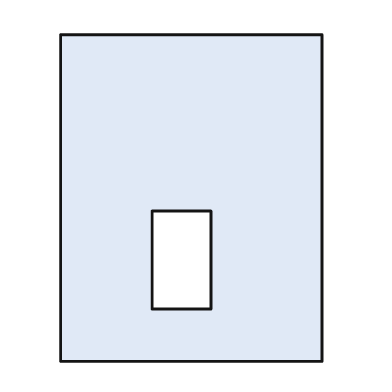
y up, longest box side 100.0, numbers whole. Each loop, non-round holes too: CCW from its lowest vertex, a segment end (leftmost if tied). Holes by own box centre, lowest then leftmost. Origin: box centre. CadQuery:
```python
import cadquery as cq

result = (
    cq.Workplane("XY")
    .moveTo(-40.0, -50.0)
    .lineTo(40.0, -50.0)
    .lineTo(40.0, 50.0)
    .lineTo(-40.0, 50.0)
    .close()
    .moveTo(-12.0, -34.0)
    .lineTo(6.0, -34.0)
    .lineTo(6.0, -4.0)
    .lineTo(-12.0, -4.0)
    .close()
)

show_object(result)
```